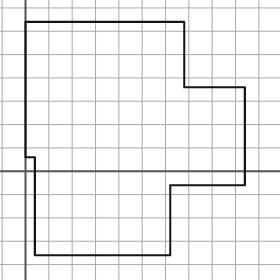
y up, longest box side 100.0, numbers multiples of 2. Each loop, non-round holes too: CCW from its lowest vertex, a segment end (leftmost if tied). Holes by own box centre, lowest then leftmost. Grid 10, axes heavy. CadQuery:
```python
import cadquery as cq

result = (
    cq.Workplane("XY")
    .moveTo(4.0, -36.0)
    .lineTo(62.0, -36.0)
    .lineTo(62.0, -6.0)
    .lineTo(94.0, -6.0)
    .lineTo(94.0, 36.0)
    .lineTo(68.0, 36.0)
    .lineTo(68.0, 64.0)
    .lineTo(0.0, 64.0)
    .lineTo(0.0, 6.0)
    .lineTo(4.0, 6.0)
    .close()
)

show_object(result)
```